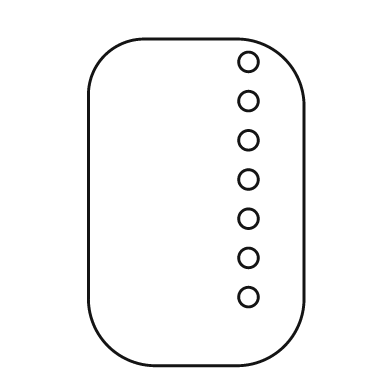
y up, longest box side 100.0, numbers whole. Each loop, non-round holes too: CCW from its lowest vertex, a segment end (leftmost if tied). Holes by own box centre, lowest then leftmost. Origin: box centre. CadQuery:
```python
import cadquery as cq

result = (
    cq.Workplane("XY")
    .moveTo(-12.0, -50.0)
    .lineTo(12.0, -50.0)
    .threePointArc((27.0, -44.0), (33.0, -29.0))
    .lineTo(33.0, 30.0)
    .threePointArc((27.0, 44.0), (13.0, 50.0))
    .lineTo(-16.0, 50.0)
    .threePointArc((-28.0, 45.0), (-33.0, 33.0))
    .lineTo(-33.0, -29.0)
    .threePointArc((-27.0, -44.0), (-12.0, -50.0))
    .close()
    .moveTo(16.0, -29.0)
    .circle(3.0)
    .moveTo(16.0, -17.0)
    .circle(3.0)
    .moveTo(16.0, -5.0)
    .circle(3.0)
    .moveTo(16.0, 7.0)
    .circle(3.0)
    .moveTo(16.0, 19.0)
    .circle(3.0)
    .moveTo(16.0, 31.0)
    .circle(3.0)
    .moveTo(16.0, 43.0)
    .circle(3.0)
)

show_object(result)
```